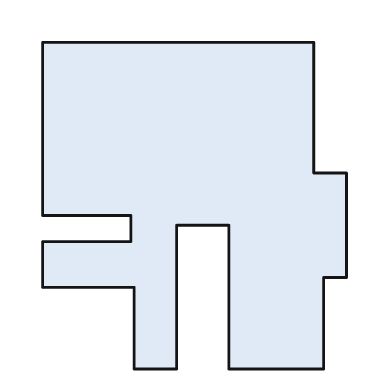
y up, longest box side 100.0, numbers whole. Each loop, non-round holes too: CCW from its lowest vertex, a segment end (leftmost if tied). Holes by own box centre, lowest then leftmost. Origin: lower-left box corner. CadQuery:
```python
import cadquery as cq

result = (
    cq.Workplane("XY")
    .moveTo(28.0, 0.0)
    .lineTo(41.0, 0.0)
    .lineTo(41.0, 44.0)
    .lineTo(57.0, 44.0)
    .lineTo(57.0, 0.0)
    .lineTo(86.0, 0.0)
    .lineTo(86.0, 28.0)
    .lineTo(93.0, 28.0)
    .lineTo(93.0, 60.0)
    .lineTo(83.0, 60.0)
    .lineTo(83.0, 100.0)
    .lineTo(0.0, 100.0)
    .lineTo(0.0, 47.0)
    .lineTo(27.0, 47.0)
    .lineTo(27.0, 39.0)
    .lineTo(0.0, 39.0)
    .lineTo(0.0, 25.0)
    .lineTo(28.0, 25.0)
    .close()
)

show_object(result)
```